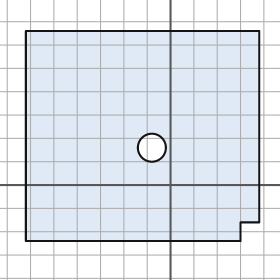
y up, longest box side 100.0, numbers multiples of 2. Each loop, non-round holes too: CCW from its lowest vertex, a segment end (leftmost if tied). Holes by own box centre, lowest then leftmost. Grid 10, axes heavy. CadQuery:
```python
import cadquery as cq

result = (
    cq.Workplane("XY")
    .moveTo(-62.0, -24.0)
    .lineTo(30.0, -24.0)
    .lineTo(30.0, -16.0)
    .lineTo(38.0, -16.0)
    .lineTo(38.0, 66.0)
    .lineTo(-62.0, 66.0)
    .close()
    .moveTo(-8.0, 16.0)
    .circle(6.0)
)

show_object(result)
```